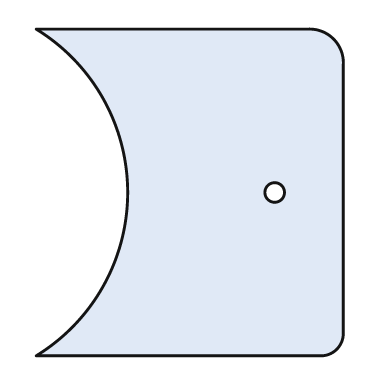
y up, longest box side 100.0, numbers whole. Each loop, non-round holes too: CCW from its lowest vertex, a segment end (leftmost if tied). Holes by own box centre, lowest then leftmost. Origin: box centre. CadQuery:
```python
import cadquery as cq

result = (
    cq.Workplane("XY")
    .moveTo(-47.0, -50.0)
    .lineTo(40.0, -50.0)
    .threePointArc((45.0, -48.0), (47.0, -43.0))
    .lineTo(47.0, 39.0)
    .threePointArc((44.0, 47.0), (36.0, 50.0))
    .lineTo(-47.0, 50.0)
    .threePointArc((-19.0, 0.0), (-47.0, -50.0))
    .close()
    .moveTo(26.0, 0.0)
    .circle(3.0)
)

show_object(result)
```